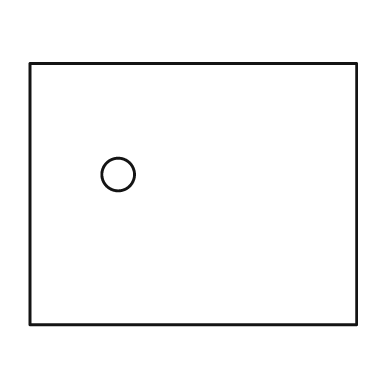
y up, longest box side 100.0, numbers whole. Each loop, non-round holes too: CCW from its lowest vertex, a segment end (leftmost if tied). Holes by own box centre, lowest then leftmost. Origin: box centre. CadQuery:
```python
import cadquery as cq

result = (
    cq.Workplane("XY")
    .moveTo(-50.0, -40.0)
    .lineTo(50.0, -40.0)
    .lineTo(50.0, 40.0)
    .lineTo(-50.0, 40.0)
    .close()
    .moveTo(-23.0, 6.0)
    .circle(5.0)
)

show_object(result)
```